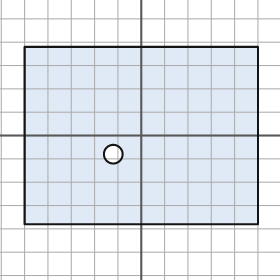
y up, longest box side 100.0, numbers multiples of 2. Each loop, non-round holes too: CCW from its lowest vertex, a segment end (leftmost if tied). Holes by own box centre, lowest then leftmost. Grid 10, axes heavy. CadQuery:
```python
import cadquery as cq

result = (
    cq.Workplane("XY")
    .moveTo(-50.0, -38.0)
    .lineTo(50.0, -38.0)
    .lineTo(50.0, 38.0)
    .lineTo(-50.0, 38.0)
    .close()
    .moveTo(-12.0, -8.0)
    .circle(4.0)
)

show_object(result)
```